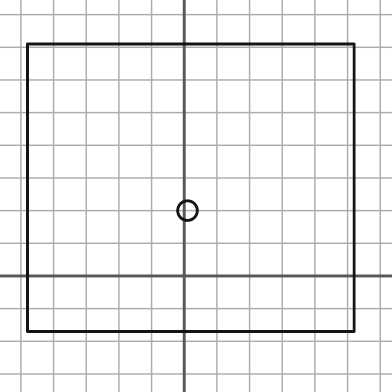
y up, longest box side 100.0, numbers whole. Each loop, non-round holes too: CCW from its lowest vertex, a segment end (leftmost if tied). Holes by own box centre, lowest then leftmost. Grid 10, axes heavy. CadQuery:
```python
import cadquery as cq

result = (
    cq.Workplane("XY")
    .moveTo(-48.0, -17.0)
    .lineTo(52.0, -17.0)
    .lineTo(52.0, 71.0)
    .lineTo(-48.0, 71.0)
    .close()
    .moveTo(1.0, 20.0)
    .circle(3.0)
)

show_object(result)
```